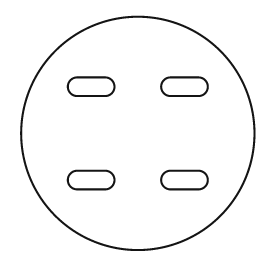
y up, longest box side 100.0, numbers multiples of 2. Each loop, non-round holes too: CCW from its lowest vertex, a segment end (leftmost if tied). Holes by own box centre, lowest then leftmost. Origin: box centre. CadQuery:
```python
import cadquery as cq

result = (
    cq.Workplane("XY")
    .moveTo(0.0, 0.0)
    .circle(50.0)
    .moveTo(-26.0, -24.0)
    .lineTo(-14.0, -24.0)
    .threePointArc((-10.0, -20.0), (-14.0, -16.0))
    .lineTo(-26.0, -16.0)
    .threePointArc((-30.0, -20.0), (-26.0, -24.0))
    .close()
    .moveTo(14.0, -24.0)
    .lineTo(26.0, -24.0)
    .threePointArc((30.0, -20.0), (26.0, -16.0))
    .lineTo(14.0, -16.0)
    .threePointArc((10.0, -20.0), (14.0, -24.0))
    .close()
    .moveTo(-26.0, 16.0)
    .lineTo(-14.0, 16.0)
    .threePointArc((-10.0, 20.0), (-14.0, 24.0))
    .lineTo(-26.0, 24.0)
    .threePointArc((-30.0, 20.0), (-26.0, 16.0))
    .close()
    .moveTo(14.0, 16.0)
    .lineTo(26.0, 16.0)
    .threePointArc((30.0, 20.0), (26.0, 24.0))
    .lineTo(14.0, 24.0)
    .threePointArc((10.0, 20.0), (14.0, 16.0))
    .close()
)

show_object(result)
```